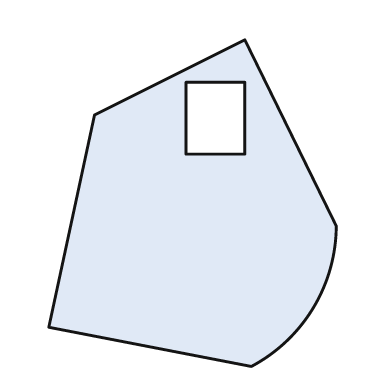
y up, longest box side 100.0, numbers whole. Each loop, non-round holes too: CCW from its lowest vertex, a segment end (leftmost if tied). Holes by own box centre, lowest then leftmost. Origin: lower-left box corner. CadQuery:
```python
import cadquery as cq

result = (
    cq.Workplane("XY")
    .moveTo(62.0, 0.0)
    .threePointArc((81.0, 18.0), (88.0, 43.0))
    .lineTo(60.0, 100.0)
    .lineTo(14.0, 77.0)
    .lineTo(0.0, 12.0)
    .close()
    .moveTo(42.0, 65.0)
    .lineTo(60.0, 65.0)
    .lineTo(60.0, 87.0)
    .lineTo(42.0, 87.0)
    .close()
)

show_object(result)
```